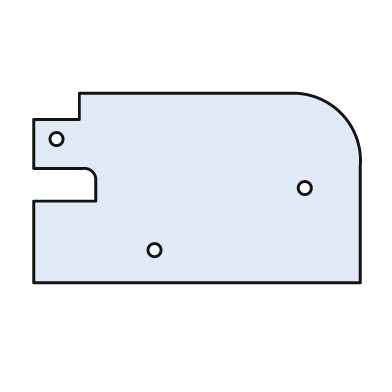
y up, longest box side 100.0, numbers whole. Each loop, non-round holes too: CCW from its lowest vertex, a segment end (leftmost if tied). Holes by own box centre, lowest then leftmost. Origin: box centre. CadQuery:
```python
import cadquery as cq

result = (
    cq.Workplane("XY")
    .moveTo(-50.0, -29.0)
    .lineTo(50.0, -29.0)
    .lineTo(50.0, 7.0)
    .threePointArc((44.0, 23.0), (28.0, 29.0))
    .lineTo(-36.0, 29.0)
    .lineTo(-36.0, 21.0)
    .lineTo(-50.0, 21.0)
    .lineTo(-50.0, 6.0)
    .lineTo(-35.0, 6.0)
    .threePointArc((-32.0, 5.0), (-31.0, 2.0))
    .lineTo(-31.0, -4.0)
    .lineTo(-50.0, -4.0)
    .close()
    .moveTo(-13.0, -19.0)
    .circle(2.0)
    .moveTo(33.0, 0.0)
    .circle(2.0)
    .moveTo(-43.0, 15.0)
    .circle(2.0)
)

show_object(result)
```